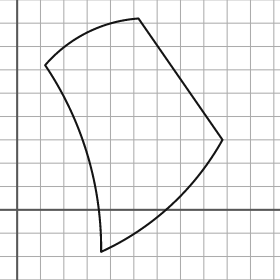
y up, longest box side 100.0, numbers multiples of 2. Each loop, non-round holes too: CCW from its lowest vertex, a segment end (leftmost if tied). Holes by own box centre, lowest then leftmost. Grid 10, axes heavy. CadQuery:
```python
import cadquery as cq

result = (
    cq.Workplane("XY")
    .moveTo(36.0, -18.0)
    .threePointArc((66.0, 2.0), (88.0, 30.0))
    .lineTo(52.0, 82.0)
    .threePointArc((30.0, 76.0), (12.0, 62.0))
    .threePointArc((30.0, 24.0), (36.0, -18.0))
    .close()
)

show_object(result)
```